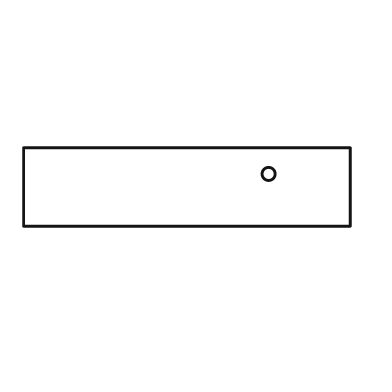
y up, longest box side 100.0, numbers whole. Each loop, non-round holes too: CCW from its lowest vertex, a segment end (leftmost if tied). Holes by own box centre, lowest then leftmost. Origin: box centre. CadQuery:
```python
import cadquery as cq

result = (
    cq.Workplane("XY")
    .moveTo(-50.0, -12.0)
    .lineTo(50.0, -12.0)
    .lineTo(50.0, 12.0)
    .lineTo(-50.0, 12.0)
    .close()
    .moveTo(25.0, 4.0)
    .circle(2.0)
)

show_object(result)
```